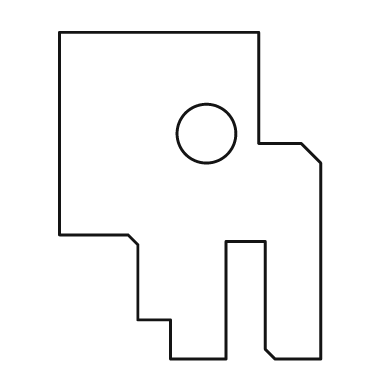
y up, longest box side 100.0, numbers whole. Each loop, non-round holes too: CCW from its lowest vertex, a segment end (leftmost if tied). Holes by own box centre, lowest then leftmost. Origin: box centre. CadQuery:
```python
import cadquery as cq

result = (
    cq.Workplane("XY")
    .moveTo(-6.0, -50.0)
    .lineTo(11.0, -50.0)
    .lineTo(11.0, -14.0)
    .lineTo(23.0, -14.0)
    .lineTo(23.0, -47.0)
    .lineTo(26.0, -50.0)
    .lineTo(40.0, -50.0)
    .lineTo(40.0, 10.0)
    .lineTo(34.0, 16.0)
    .lineTo(21.0, 16.0)
    .lineTo(21.0, 50.0)
    .lineTo(-40.0, 50.0)
    .lineTo(-40.0, -12.0)
    .lineTo(-19.0, -12.0)
    .lineTo(-16.0, -15.0)
    .lineTo(-16.0, -38.0)
    .lineTo(-6.0, -38.0)
    .close()
    .moveTo(5.0, 19.0)
    .circle(9.0)
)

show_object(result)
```